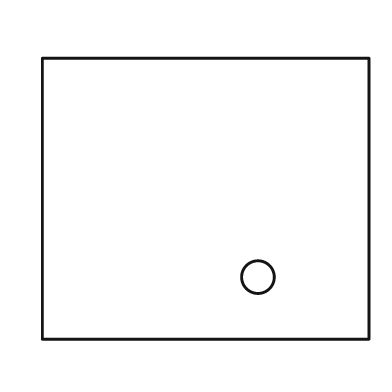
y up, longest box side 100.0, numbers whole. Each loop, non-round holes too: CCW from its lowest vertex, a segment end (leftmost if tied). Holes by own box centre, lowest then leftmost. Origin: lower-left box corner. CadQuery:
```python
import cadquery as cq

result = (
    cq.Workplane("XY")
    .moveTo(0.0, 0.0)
    .lineTo(100.0, 0.0)
    .lineTo(100.0, 86.0)
    .lineTo(0.0, 86.0)
    .close()
    .moveTo(66.0, 19.0)
    .circle(5.0)
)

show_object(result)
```